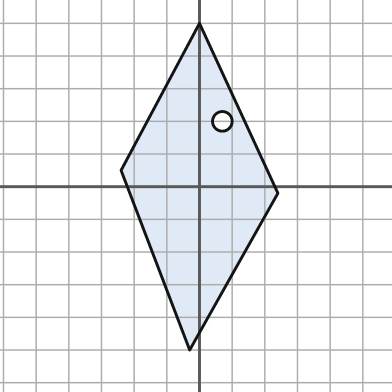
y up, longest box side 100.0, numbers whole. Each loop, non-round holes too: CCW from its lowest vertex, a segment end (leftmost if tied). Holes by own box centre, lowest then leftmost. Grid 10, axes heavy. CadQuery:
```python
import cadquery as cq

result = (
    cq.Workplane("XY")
    .moveTo(-3.0, -50.0)
    .lineTo(24.0, -2.0)
    .lineTo(0.0, 50.0)
    .lineTo(-24.0, 5.0)
    .close()
    .moveTo(7.0, 20.0)
    .circle(3.0)
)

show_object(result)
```